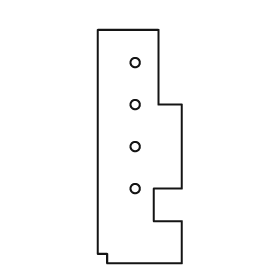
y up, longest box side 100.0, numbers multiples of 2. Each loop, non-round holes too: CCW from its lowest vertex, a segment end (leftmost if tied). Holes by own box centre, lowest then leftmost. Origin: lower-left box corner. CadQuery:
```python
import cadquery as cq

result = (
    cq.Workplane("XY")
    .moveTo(4.0, 0.0)
    .lineTo(36.0, 0.0)
    .lineTo(36.0, 18.0)
    .lineTo(24.0, 18.0)
    .lineTo(24.0, 32.0)
    .lineTo(36.0, 32.0)
    .lineTo(36.0, 68.0)
    .lineTo(26.0, 68.0)
    .lineTo(26.0, 100.0)
    .lineTo(0.0, 100.0)
    .lineTo(0.0, 4.0)
    .lineTo(4.0, 4.0)
    .close()
    .moveTo(16.0, 32.0)
    .circle(2.0)
    .moveTo(16.0, 50.0)
    .circle(2.0)
    .moveTo(16.0, 68.0)
    .circle(2.0)
    .moveTo(16.0, 86.0)
    .circle(2.0)
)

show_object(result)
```